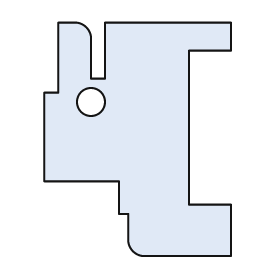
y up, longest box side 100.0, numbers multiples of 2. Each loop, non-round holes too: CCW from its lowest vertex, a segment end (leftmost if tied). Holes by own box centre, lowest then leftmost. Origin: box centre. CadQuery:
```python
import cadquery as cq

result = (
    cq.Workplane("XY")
    .moveTo(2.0, -50.0)
    .lineTo(40.0, -50.0)
    .lineTo(40.0, -28.0)
    .lineTo(22.0, -28.0)
    .lineTo(22.0, 38.0)
    .lineTo(40.0, 38.0)
    .lineTo(40.0, 50.0)
    .lineTo(-14.0, 50.0)
    .lineTo(-14.0, 26.0)
    .lineTo(-20.0, 26.0)
    .lineTo(-20.0, 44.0)
    .threePointArc((-22.0, 48.0), (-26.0, 50.0))
    .lineTo(-34.0, 50.0)
    .lineTo(-34.0, 20.0)
    .lineTo(-40.0, 20.0)
    .lineTo(-40.0, -18.0)
    .lineTo(-8.0, -18.0)
    .lineTo(-8.0, -32.0)
    .lineTo(-4.0, -32.0)
    .lineTo(-4.0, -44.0)
    .threePointArc((-2.0, -48.0), (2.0, -50.0))
    .close()
    .moveTo(-20.0, 16.0)
    .circle(6.0)
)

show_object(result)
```